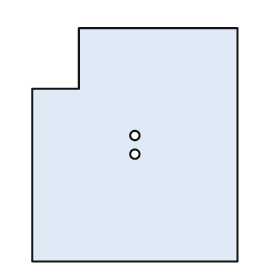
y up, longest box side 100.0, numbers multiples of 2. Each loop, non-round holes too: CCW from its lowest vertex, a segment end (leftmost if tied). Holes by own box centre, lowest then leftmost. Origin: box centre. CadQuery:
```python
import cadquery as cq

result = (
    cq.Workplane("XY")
    .moveTo(-44.0, -50.0)
    .lineTo(44.0, -50.0)
    .lineTo(44.0, 50.0)
    .lineTo(-24.0, 50.0)
    .lineTo(-24.0, 24.0)
    .lineTo(-44.0, 24.0)
    .close()
    .moveTo(0.0, -4.0)
    .circle(2.0)
    .moveTo(0.0, 4.0)
    .circle(2.0)
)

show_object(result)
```